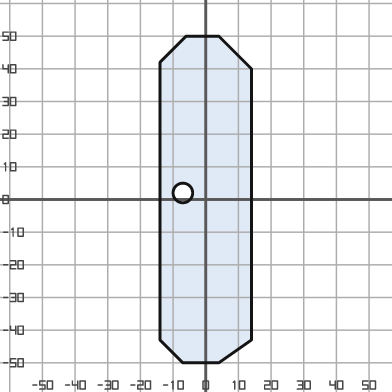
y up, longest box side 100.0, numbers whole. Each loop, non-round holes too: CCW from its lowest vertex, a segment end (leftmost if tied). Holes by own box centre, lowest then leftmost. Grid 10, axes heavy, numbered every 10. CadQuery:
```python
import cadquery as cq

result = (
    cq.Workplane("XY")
    .moveTo(-7.0, -50.0)
    .lineTo(4.0, -50.0)
    .lineTo(14.0, -43.0)
    .lineTo(14.0, 40.0)
    .lineTo(4.0, 50.0)
    .lineTo(-6.0, 50.0)
    .lineTo(-14.0, 42.0)
    .lineTo(-14.0, -43.0)
    .close()
    .moveTo(-7.0, 2.0)
    .circle(3.0)
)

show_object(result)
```